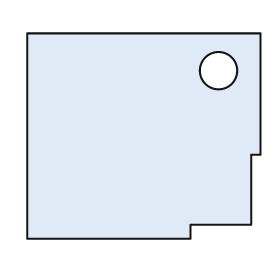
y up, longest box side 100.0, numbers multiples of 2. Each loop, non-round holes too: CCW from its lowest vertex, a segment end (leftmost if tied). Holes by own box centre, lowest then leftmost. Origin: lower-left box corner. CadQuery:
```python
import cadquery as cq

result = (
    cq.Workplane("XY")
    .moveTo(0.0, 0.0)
    .lineTo(70.0, 0.0)
    .lineTo(70.0, 6.0)
    .lineTo(96.0, 6.0)
    .lineTo(96.0, 36.0)
    .lineTo(100.0, 36.0)
    .lineTo(100.0, 88.0)
    .lineTo(0.0, 88.0)
    .close()
    .moveTo(82.0, 72.0)
    .circle(8.0)
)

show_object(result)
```